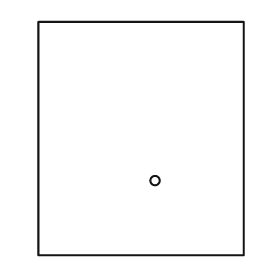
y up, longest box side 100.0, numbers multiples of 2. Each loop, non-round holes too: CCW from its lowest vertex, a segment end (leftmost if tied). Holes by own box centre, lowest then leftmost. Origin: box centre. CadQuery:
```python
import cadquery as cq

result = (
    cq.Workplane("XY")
    .moveTo(-44.0, -50.0)
    .lineTo(44.0, -50.0)
    .lineTo(44.0, 50.0)
    .lineTo(-44.0, 50.0)
    .close()
    .moveTo(6.0, -18.0)
    .circle(2.0)
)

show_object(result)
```